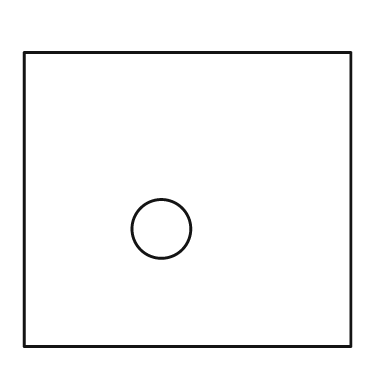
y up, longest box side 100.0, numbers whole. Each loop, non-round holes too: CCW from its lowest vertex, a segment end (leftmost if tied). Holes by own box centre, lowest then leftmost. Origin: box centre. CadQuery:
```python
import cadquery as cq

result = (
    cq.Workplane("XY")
    .moveTo(-50.0, -45.0)
    .lineTo(50.0, -45.0)
    .lineTo(50.0, 45.0)
    .lineTo(-50.0, 45.0)
    .close()
    .moveTo(-8.0, -9.0)
    .circle(9.0)
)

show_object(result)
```